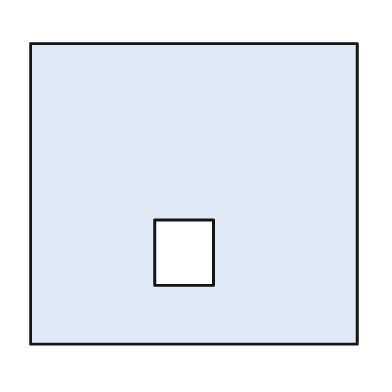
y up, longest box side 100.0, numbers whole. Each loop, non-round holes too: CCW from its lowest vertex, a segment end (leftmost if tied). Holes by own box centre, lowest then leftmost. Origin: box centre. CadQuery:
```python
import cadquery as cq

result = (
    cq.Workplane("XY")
    .moveTo(-50.0, -46.0)
    .lineTo(50.0, -46.0)
    .lineTo(50.0, 46.0)
    .lineTo(-50.0, 46.0)
    .close()
    .moveTo(-12.0, -28.0)
    .lineTo(6.0, -28.0)
    .lineTo(6.0, -8.0)
    .lineTo(-12.0, -8.0)
    .close()
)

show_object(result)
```